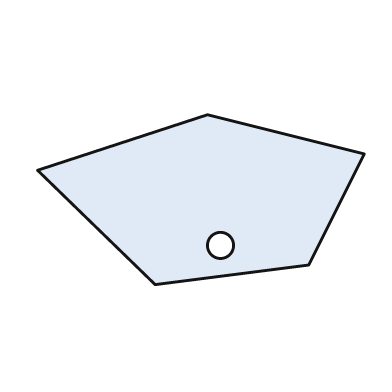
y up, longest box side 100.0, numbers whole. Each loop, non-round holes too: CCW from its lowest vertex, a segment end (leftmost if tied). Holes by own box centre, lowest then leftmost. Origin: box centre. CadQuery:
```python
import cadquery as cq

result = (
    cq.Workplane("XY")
    .moveTo(-14.0, -26.0)
    .lineTo(33.0, -20.0)
    .lineTo(50.0, 14.0)
    .lineTo(2.0, 26.0)
    .lineTo(-50.0, 9.0)
    .close()
    .moveTo(6.0, -14.0)
    .circle(4.0)
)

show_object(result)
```